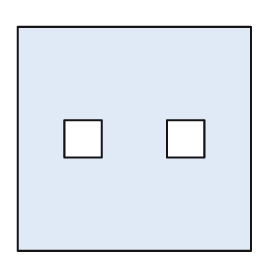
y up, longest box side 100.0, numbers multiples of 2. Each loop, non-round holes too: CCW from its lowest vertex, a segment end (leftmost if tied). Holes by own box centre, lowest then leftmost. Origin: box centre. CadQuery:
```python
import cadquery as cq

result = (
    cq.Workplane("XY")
    .moveTo(-50.0, -48.0)
    .lineTo(50.0, -48.0)
    .lineTo(50.0, 48.0)
    .lineTo(-50.0, 48.0)
    .close()
    .moveTo(-30.0, -8.0)
    .lineTo(-14.0, -8.0)
    .lineTo(-14.0, 8.0)
    .lineTo(-30.0, 8.0)
    .close()
    .moveTo(14.0, -8.0)
    .lineTo(30.0, -8.0)
    .lineTo(30.0, 8.0)
    .lineTo(14.0, 8.0)
    .close()
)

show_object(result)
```